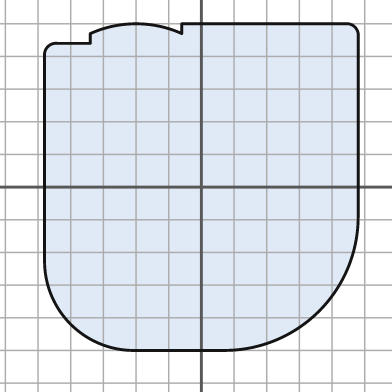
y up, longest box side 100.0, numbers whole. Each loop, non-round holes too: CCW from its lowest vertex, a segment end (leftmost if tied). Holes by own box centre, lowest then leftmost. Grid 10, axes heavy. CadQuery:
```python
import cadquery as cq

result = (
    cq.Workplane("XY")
    .moveTo(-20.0, -50.0)
    .lineTo(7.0, -50.0)
    .threePointArc((36.0, -38.0), (48.0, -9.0))
    .lineTo(48.0, 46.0)
    .threePointArc((47.0, 49.0), (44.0, 50.0))
    .lineTo(-6.0, 50.0)
    .lineTo(-6.0, 47.0)
    .threePointArc((-20.0, 50.0), (-34.0, 47.0))
    .lineTo(-34.0, 44.0)
    .lineTo(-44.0, 44.0)
    .threePointArc((-47.0, 43.0), (-48.0, 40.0))
    .lineTo(-48.0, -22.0)
    .threePointArc((-40.0, -42.0), (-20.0, -50.0))
    .close()
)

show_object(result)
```